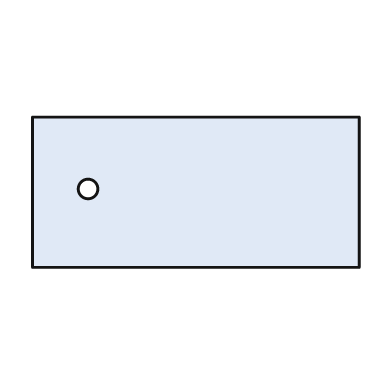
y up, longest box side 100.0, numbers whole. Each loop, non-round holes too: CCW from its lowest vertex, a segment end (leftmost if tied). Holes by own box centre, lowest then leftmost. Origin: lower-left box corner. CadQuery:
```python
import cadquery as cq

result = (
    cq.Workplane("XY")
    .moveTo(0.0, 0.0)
    .lineTo(100.0, 0.0)
    .lineTo(100.0, 46.0)
    .lineTo(0.0, 46.0)
    .close()
    .moveTo(17.0, 24.0)
    .circle(3.0)
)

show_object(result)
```